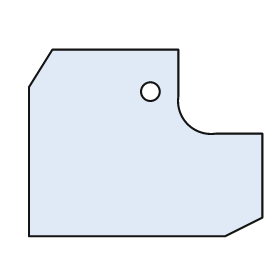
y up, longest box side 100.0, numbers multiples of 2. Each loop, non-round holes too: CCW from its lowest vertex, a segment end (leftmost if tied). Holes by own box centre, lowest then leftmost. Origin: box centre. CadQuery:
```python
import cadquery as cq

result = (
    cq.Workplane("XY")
    .moveTo(-50.0, -40.0)
    .lineTo(34.0, -40.0)
    .lineTo(50.0, -32.0)
    .lineTo(50.0, 4.0)
    .lineTo(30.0, 4.0)
    .threePointArc((18.0, 8.0), (14.0, 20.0))
    .lineTo(14.0, 40.0)
    .lineTo(-40.0, 40.0)
    .lineTo(-50.0, 24.0)
    .close()
    .moveTo(2.0, 22.0)
    .circle(4.0)
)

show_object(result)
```